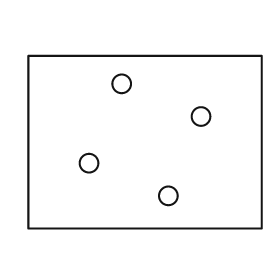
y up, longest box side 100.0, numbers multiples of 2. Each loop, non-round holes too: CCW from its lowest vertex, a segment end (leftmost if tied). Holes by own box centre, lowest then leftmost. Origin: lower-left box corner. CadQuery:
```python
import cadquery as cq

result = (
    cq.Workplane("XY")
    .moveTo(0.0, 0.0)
    .lineTo(100.0, 0.0)
    .lineTo(100.0, 74.0)
    .lineTo(0.0, 74.0)
    .close()
    .moveTo(60.0, 14.0)
    .circle(4.0)
    .moveTo(26.0, 28.0)
    .circle(4.0)
    .moveTo(74.0, 48.0)
    .circle(4.0)
    .moveTo(40.0, 62.0)
    .circle(4.0)
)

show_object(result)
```